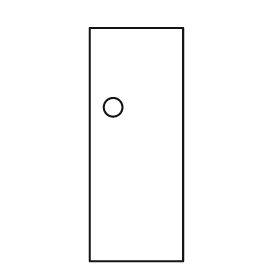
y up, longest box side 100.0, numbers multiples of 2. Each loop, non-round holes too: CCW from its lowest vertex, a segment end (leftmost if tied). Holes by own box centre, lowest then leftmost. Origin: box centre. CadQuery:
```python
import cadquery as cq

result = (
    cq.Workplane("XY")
    .moveTo(-20.0, -50.0)
    .lineTo(20.0, -50.0)
    .lineTo(20.0, 50.0)
    .lineTo(-20.0, 50.0)
    .close()
    .moveTo(-10.0, 16.0)
    .circle(4.0)
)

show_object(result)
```